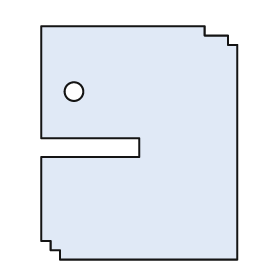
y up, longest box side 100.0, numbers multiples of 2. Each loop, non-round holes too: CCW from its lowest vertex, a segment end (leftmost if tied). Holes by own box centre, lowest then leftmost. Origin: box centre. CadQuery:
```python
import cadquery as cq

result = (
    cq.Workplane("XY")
    .moveTo(-34.0, -50.0)
    .lineTo(42.0, -50.0)
    .lineTo(42.0, 42.0)
    .lineTo(38.0, 42.0)
    .lineTo(38.0, 46.0)
    .lineTo(28.0, 46.0)
    .lineTo(28.0, 50.0)
    .lineTo(-42.0, 50.0)
    .lineTo(-42.0, 2.0)
    .lineTo(0.0, 2.0)
    .lineTo(0.0, -6.0)
    .lineTo(-42.0, -6.0)
    .lineTo(-42.0, -42.0)
    .lineTo(-38.0, -42.0)
    .lineTo(-38.0, -46.0)
    .lineTo(-34.0, -46.0)
    .close()
    .moveTo(-28.0, 22.0)
    .circle(4.0)
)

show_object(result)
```